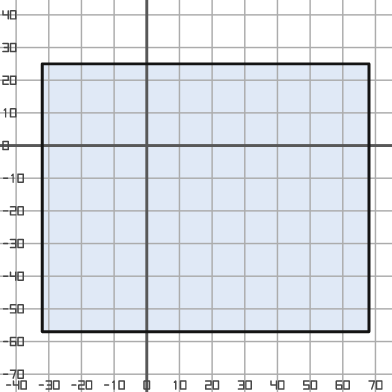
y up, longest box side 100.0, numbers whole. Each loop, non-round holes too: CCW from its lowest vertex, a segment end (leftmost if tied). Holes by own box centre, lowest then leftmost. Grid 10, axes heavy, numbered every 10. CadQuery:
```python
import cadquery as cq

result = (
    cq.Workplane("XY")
    .moveTo(-32.0, -57.0)
    .lineTo(68.0, -57.0)
    .lineTo(68.0, 25.0)
    .lineTo(-32.0, 25.0)
    .close()
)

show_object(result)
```